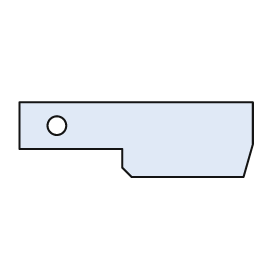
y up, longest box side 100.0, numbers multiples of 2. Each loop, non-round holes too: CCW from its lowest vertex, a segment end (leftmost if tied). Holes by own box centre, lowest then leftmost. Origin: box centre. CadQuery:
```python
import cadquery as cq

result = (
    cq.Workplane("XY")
    .moveTo(-2.0, -16.0)
    .lineTo(46.0, -16.0)
    .lineTo(50.0, -2.0)
    .lineTo(50.0, 16.0)
    .lineTo(-50.0, 16.0)
    .lineTo(-50.0, -4.0)
    .lineTo(-6.0, -4.0)
    .lineTo(-6.0, -12.0)
    .close()
    .moveTo(-34.0, 6.0)
    .circle(4.0)
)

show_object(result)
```